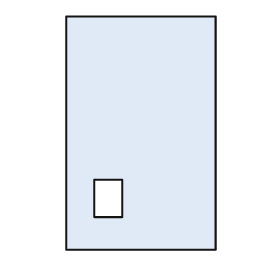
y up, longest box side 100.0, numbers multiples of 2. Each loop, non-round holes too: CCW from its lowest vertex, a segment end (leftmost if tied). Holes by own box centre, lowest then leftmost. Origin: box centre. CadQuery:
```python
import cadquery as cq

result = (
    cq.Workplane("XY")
    .moveTo(-32.0, -50.0)
    .lineTo(32.0, -50.0)
    .lineTo(32.0, 50.0)
    .lineTo(-32.0, 50.0)
    .close()
    .moveTo(-20.0, -36.0)
    .lineTo(-8.0, -36.0)
    .lineTo(-8.0, -20.0)
    .lineTo(-20.0, -20.0)
    .close()
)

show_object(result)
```